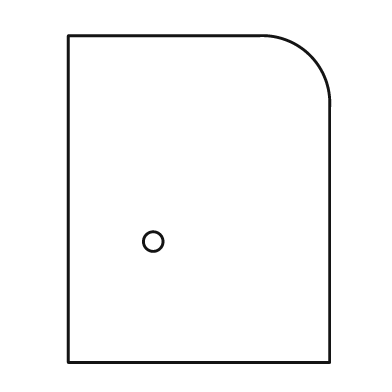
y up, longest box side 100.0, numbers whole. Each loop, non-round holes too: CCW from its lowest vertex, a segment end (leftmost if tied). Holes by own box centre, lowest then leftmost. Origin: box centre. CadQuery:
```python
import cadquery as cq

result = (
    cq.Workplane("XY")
    .moveTo(-40.0, -50.0)
    .lineTo(40.0, -50.0)
    .lineTo(40.0, 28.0)
    .threePointArc((34.0, 44.0), (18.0, 50.0))
    .lineTo(-40.0, 50.0)
    .close()
    .moveTo(-14.0, -13.0)
    .circle(3.0)
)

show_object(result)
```